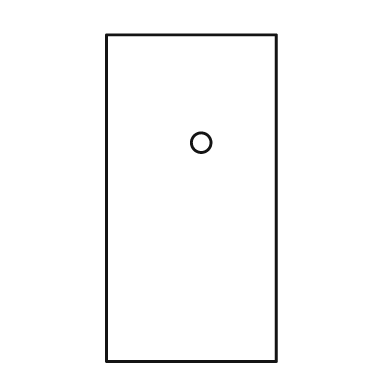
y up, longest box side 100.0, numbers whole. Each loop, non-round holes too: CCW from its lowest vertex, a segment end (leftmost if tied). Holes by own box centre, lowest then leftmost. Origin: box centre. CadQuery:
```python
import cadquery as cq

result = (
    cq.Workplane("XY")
    .moveTo(-26.0, -50.0)
    .lineTo(26.0, -50.0)
    .lineTo(26.0, 50.0)
    .lineTo(-26.0, 50.0)
    .close()
    .moveTo(3.0, 17.0)
    .circle(3.0)
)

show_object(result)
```